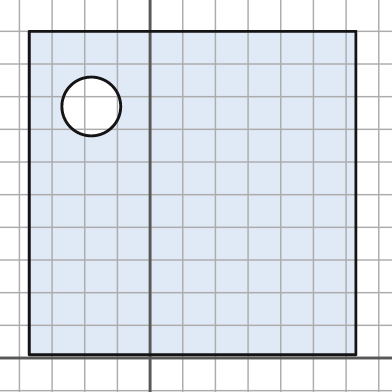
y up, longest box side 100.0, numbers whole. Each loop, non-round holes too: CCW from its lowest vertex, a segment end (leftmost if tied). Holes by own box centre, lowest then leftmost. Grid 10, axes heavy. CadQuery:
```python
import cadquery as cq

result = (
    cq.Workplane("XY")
    .moveTo(-37.0, 1.0)
    .lineTo(63.0, 1.0)
    .lineTo(63.0, 100.0)
    .lineTo(-37.0, 100.0)
    .close()
    .moveTo(-18.0, 77.0)
    .circle(9.0)
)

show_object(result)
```